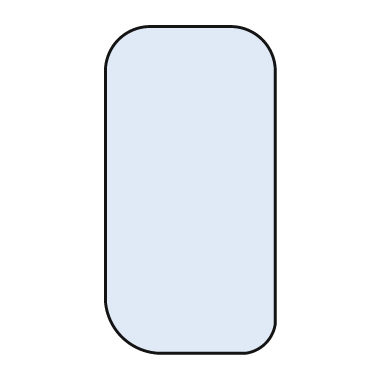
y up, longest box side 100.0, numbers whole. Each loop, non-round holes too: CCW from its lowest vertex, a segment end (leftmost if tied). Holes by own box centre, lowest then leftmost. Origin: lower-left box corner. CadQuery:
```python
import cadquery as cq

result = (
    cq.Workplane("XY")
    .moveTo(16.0, 0.0)
    .lineTo(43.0, 0.0)
    .threePointArc((49.0, 3.0), (52.0, 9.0))
    .lineTo(52.0, 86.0)
    .threePointArc((48.0, 96.0), (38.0, 100.0))
    .lineTo(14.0, 100.0)
    .threePointArc((4.0, 96.0), (0.0, 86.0))
    .lineTo(0.0, 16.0)
    .threePointArc((5.0, 5.0), (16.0, 0.0))
    .close()
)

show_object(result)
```